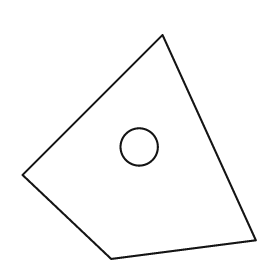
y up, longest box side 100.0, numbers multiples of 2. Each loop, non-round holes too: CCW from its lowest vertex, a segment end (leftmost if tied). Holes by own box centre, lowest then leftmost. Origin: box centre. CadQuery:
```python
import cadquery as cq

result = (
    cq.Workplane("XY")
    .moveTo(-12.0, -48.0)
    .lineTo(50.0, -40.0)
    .lineTo(10.0, 48.0)
    .lineTo(-50.0, -12.0)
    .close()
    .moveTo(0.0, 0.0)
    .circle(8.0)
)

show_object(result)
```